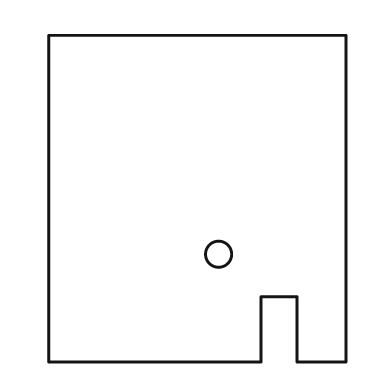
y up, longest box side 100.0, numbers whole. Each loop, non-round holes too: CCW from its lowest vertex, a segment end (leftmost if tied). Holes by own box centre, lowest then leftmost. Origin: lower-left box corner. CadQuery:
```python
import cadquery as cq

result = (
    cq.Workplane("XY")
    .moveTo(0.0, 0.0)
    .lineTo(65.0, 0.0)
    .lineTo(65.0, 20.0)
    .lineTo(76.0, 20.0)
    .lineTo(76.0, 0.0)
    .lineTo(91.0, 0.0)
    .lineTo(91.0, 100.0)
    .lineTo(0.0, 100.0)
    .close()
    .moveTo(52.0, 33.0)
    .circle(4.0)
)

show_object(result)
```